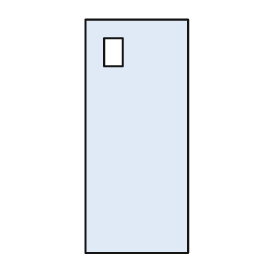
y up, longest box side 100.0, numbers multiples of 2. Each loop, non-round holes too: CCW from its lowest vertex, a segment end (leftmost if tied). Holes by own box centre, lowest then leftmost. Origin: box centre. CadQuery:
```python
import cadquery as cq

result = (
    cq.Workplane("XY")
    .moveTo(-22.0, -50.0)
    .lineTo(22.0, -50.0)
    .lineTo(22.0, 50.0)
    .lineTo(-22.0, 50.0)
    .close()
    .moveTo(-14.0, 30.0)
    .lineTo(-6.0, 30.0)
    .lineTo(-6.0, 42.0)
    .lineTo(-14.0, 42.0)
    .close()
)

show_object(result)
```